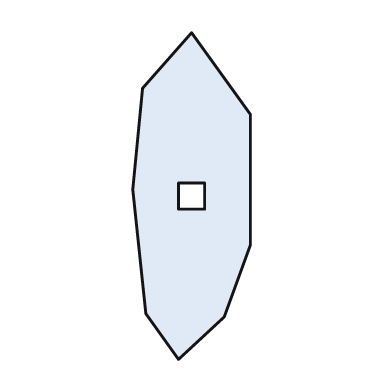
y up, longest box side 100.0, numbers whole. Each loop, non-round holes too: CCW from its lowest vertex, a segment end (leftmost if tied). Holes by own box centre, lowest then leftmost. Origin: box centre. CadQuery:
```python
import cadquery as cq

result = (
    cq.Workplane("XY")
    .moveTo(-4.0, -50.0)
    .lineTo(10.0, -37.0)
    .lineTo(18.0, -15.0)
    .lineTo(18.0, 25.0)
    .lineTo(0.0, 50.0)
    .lineTo(-15.0, 33.0)
    .lineTo(-18.0, 2.0)
    .lineTo(-14.0, -36.0)
    .close()
    .moveTo(-4.0, -4.0)
    .lineTo(4.0, -4.0)
    .lineTo(4.0, 4.0)
    .lineTo(-4.0, 4.0)
    .close()
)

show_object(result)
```